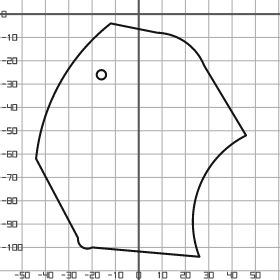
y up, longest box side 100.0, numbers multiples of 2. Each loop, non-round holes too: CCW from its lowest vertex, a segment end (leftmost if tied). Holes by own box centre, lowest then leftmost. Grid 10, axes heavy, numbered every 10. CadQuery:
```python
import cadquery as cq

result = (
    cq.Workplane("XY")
    .moveTo(26.0, -104.0)
    .threePointArc((26.0, -74.0), (46.0, -52.0))
    .lineTo(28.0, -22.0)
    .threePointArc((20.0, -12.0), (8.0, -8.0))
    .lineTo(-12.0, -4.0)
    .threePointArc((-34.0, -30.0), (-44.0, -62.0))
    .lineTo(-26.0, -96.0)
    .threePointArc((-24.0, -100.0), (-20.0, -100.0))
    .close()
    .moveTo(-16.0, -26.0)
    .circle(2.0)
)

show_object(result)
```